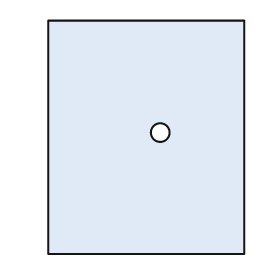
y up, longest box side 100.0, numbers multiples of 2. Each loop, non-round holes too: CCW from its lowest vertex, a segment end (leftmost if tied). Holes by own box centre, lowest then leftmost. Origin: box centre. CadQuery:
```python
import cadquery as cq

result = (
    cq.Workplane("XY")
    .moveTo(-42.0, -50.0)
    .lineTo(42.0, -50.0)
    .lineTo(42.0, 50.0)
    .lineTo(-42.0, 50.0)
    .close()
    .moveTo(6.0, 2.0)
    .circle(4.0)
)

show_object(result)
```